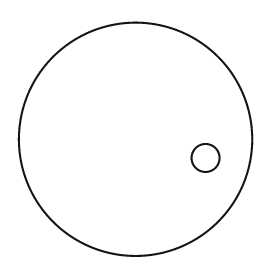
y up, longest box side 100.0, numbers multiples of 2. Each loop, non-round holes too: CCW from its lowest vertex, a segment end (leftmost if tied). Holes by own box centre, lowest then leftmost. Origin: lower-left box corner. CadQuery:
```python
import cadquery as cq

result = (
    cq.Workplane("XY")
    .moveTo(50.0, 50.0)
    .circle(50.0)
    .moveTo(80.0, 42.0)
    .circle(6.0)
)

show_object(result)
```